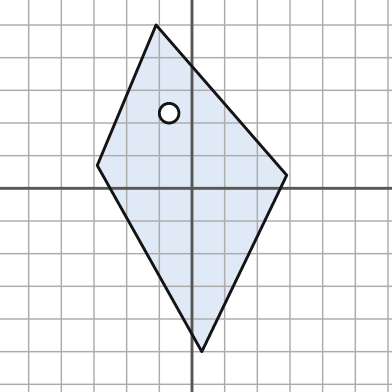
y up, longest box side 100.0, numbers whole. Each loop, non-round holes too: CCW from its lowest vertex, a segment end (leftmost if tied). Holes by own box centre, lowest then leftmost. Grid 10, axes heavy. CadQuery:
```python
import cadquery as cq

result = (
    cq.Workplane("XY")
    .moveTo(3.0, -50.0)
    .lineTo(29.0, 4.0)
    .lineTo(-11.0, 50.0)
    .lineTo(-29.0, 7.0)
    .close()
    .moveTo(-7.0, 23.0)
    .circle(3.0)
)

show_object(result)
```